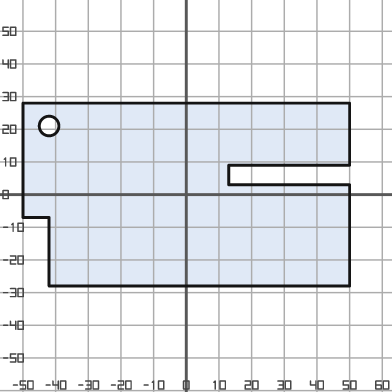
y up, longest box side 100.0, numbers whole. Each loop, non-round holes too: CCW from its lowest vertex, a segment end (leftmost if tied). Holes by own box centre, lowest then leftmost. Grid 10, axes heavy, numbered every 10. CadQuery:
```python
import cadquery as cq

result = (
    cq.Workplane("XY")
    .moveTo(-42.0, -28.0)
    .lineTo(50.0, -28.0)
    .lineTo(50.0, 3.0)
    .lineTo(13.0, 3.0)
    .lineTo(13.0, 9.0)
    .lineTo(50.0, 9.0)
    .lineTo(50.0, 28.0)
    .lineTo(-50.0, 28.0)
    .lineTo(-50.0, -7.0)
    .lineTo(-42.0, -7.0)
    .close()
    .moveTo(-42.0, 21.0)
    .circle(3.0)
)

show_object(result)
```